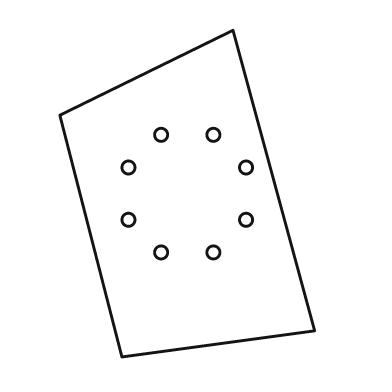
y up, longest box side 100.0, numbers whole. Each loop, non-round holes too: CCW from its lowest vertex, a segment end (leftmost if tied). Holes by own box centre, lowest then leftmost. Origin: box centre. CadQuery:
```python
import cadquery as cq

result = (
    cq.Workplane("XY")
    .moveTo(-20.0, -50.0)
    .lineTo(39.0, -42.0)
    .lineTo(14.0, 50.0)
    .lineTo(-39.0, 24.0)
    .close()
    .moveTo(-8.0, -18.0)
    .circle(2.0)
    .moveTo(8.0, -18.0)
    .circle(2.0)
    .moveTo(-18.0, -8.0)
    .circle(2.0)
    .moveTo(18.0, -8.0)
    .circle(2.0)
    .moveTo(-18.0, 8.0)
    .circle(2.0)
    .moveTo(18.0, 8.0)
    .circle(2.0)
    .moveTo(-8.0, 18.0)
    .circle(2.0)
    .moveTo(8.0, 18.0)
    .circle(2.0)
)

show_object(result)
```